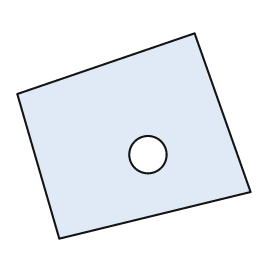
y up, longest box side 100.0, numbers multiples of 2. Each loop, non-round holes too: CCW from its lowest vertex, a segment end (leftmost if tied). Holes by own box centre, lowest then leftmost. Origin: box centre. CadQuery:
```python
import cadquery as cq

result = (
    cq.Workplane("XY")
    .moveTo(-32.0, -44.0)
    .lineTo(50.0, -24.0)
    .lineTo(26.0, 44.0)
    .lineTo(-50.0, 18.0)
    .close()
    .moveTo(6.0, -8.0)
    .circle(8.0)
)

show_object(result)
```